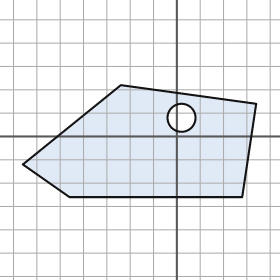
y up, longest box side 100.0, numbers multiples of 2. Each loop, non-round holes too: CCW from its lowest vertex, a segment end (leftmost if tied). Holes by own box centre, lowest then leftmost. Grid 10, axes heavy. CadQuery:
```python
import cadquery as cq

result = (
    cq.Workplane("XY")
    .moveTo(-46.0, -26.0)
    .lineTo(28.0, -26.0)
    .lineTo(34.0, 14.0)
    .lineTo(-24.0, 22.0)
    .lineTo(-66.0, -12.0)
    .close()
    .moveTo(2.0, 8.0)
    .circle(6.0)
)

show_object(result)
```